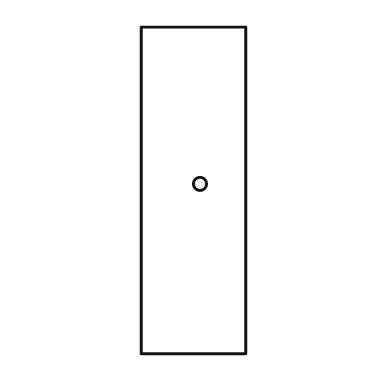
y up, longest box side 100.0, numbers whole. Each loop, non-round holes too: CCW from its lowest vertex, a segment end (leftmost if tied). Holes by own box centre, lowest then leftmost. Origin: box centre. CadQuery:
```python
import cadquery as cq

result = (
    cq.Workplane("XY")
    .moveTo(-16.0, -50.0)
    .lineTo(16.0, -50.0)
    .lineTo(16.0, 50.0)
    .lineTo(-16.0, 50.0)
    .close()
    .moveTo(2.0, 2.0)
    .circle(2.0)
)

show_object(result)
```